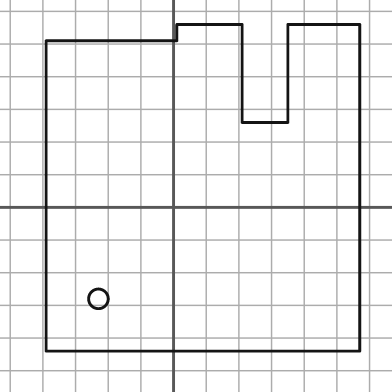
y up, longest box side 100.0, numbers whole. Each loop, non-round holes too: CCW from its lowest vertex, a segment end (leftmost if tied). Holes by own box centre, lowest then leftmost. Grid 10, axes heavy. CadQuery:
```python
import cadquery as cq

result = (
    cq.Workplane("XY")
    .moveTo(-39.0, -44.0)
    .lineTo(57.0, -44.0)
    .lineTo(57.0, 56.0)
    .lineTo(35.0, 56.0)
    .lineTo(35.0, 26.0)
    .lineTo(21.0, 26.0)
    .lineTo(21.0, 56.0)
    .lineTo(1.0, 56.0)
    .lineTo(1.0, 51.0)
    .lineTo(-39.0, 51.0)
    .close()
    .moveTo(-23.0, -28.0)
    .circle(3.0)
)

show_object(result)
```